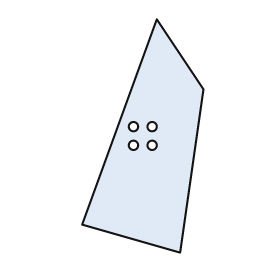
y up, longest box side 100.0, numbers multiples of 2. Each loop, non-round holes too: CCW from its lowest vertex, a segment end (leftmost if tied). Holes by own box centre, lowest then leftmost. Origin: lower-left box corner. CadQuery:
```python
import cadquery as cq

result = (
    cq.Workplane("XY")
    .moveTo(42.0, 0.0)
    .lineTo(52.0, 70.0)
    .lineTo(32.0, 100.0)
    .lineTo(0.0, 12.0)
    .close()
    .moveTo(22.0, 46.0)
    .circle(2.0)
    .moveTo(30.0, 46.0)
    .circle(2.0)
    .moveTo(22.0, 54.0)
    .circle(2.0)
    .moveTo(30.0, 54.0)
    .circle(2.0)
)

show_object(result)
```